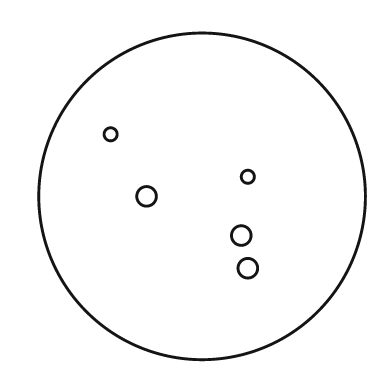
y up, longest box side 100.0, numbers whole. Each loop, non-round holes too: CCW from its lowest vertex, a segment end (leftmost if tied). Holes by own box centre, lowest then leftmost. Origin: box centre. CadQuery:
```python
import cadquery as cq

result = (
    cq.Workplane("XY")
    .moveTo(0.0, 0.0)
    .circle(50.0)
    .moveTo(14.0, -22.0)
    .circle(3.0)
    .moveTo(12.0, -12.0)
    .circle(3.0)
    .moveTo(-17.0, 0.0)
    .circle(3.0)
    .moveTo(14.0, 6.0)
    .circle(2.0)
    .moveTo(-28.0, 19.0)
    .circle(2.0)
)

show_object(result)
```